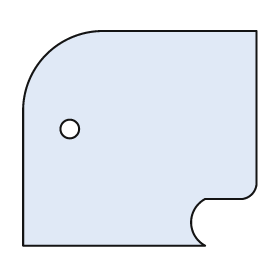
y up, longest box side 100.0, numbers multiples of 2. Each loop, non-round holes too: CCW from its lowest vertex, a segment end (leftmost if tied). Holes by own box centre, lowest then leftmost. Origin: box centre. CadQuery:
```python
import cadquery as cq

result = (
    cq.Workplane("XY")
    .moveTo(-50.0, -46.0)
    .lineTo(28.0, -46.0)
    .threePointArc((22.0, -36.0), (28.0, -26.0))
    .lineTo(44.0, -26.0)
    .threePointArc((48.0, -24.0), (50.0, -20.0))
    .lineTo(50.0, 46.0)
    .lineTo(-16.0, 46.0)
    .threePointArc((-40.0, 36.0), (-50.0, 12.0))
    .close()
    .moveTo(-30.0, 4.0)
    .circle(4.0)
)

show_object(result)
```